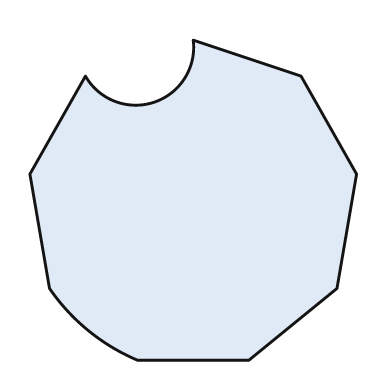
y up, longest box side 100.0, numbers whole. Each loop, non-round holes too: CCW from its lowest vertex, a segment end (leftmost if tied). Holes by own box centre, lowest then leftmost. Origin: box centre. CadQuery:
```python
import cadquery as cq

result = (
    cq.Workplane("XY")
    .moveTo(-17.0, -49.0)
    .lineTo(17.0, -49.0)
    .lineTo(44.0, -27.0)
    .lineTo(50.0, 8.0)
    .lineTo(33.0, 38.0)
    .lineTo(0.0, 49.0)
    .threePointArc((-12.0, 30.0), (-33.0, 38.0))
    .lineTo(-50.0, 8.0)
    .lineTo(-44.0, -27.0)
    .threePointArc((-32.0, -40.0), (-17.0, -49.0))
    .close()
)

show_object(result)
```